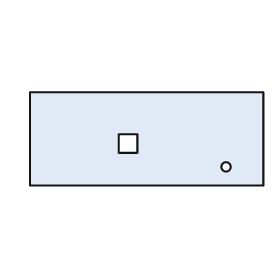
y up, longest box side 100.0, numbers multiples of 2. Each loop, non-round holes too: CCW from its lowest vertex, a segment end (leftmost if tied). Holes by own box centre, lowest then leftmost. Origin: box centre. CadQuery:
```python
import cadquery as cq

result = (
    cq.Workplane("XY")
    .moveTo(-50.0, -20.0)
    .lineTo(50.0, -20.0)
    .lineTo(50.0, 20.0)
    .lineTo(-50.0, 20.0)
    .close()
    .moveTo(34.0, -12.0)
    .circle(2.0)
    .moveTo(-12.0, -6.0)
    .lineTo(-4.0, -6.0)
    .lineTo(-4.0, 2.0)
    .lineTo(-12.0, 2.0)
    .close()
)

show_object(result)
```